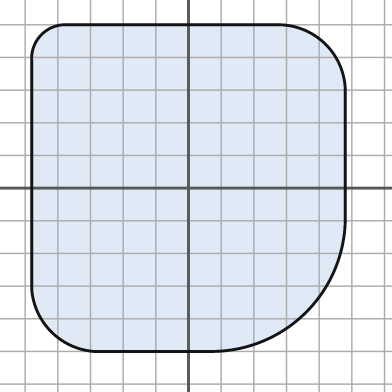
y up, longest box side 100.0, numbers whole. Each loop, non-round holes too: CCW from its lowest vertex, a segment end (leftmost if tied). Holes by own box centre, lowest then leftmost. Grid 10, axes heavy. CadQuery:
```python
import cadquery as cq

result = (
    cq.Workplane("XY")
    .moveTo(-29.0, -50.0)
    .lineTo(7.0, -50.0)
    .threePointArc((36.0, -38.0), (48.0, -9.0))
    .lineTo(48.0, 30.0)
    .threePointArc((42.0, 44.0), (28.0, 50.0))
    .lineTo(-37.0, 50.0)
    .threePointArc((-45.0, 47.0), (-48.0, 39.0))
    .lineTo(-48.0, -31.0)
    .threePointArc((-42.0, -44.0), (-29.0, -50.0))
    .close()
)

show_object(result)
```